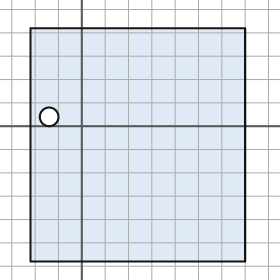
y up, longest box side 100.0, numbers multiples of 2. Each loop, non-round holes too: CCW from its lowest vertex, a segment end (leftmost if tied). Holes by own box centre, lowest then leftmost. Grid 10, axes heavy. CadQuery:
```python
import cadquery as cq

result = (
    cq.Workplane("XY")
    .moveTo(-22.0, -58.0)
    .lineTo(70.0, -58.0)
    .lineTo(70.0, 42.0)
    .lineTo(-22.0, 42.0)
    .close()
    .moveTo(-14.0, 4.0)
    .circle(4.0)
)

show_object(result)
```